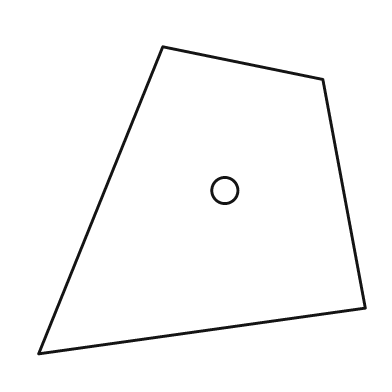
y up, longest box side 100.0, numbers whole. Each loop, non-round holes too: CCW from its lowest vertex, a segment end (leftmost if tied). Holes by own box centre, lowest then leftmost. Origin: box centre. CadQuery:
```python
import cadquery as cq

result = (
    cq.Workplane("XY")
    .moveTo(-50.0, -47.0)
    .lineTo(50.0, -33.0)
    .lineTo(37.0, 37.0)
    .lineTo(-12.0, 47.0)
    .close()
    .moveTo(7.0, 3.0)
    .circle(4.0)
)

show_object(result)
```